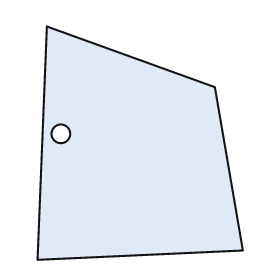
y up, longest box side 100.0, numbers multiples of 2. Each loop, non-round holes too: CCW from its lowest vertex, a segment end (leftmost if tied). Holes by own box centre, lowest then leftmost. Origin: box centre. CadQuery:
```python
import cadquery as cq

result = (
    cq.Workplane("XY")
    .moveTo(-44.0, -50.0)
    .lineTo(44.0, -46.0)
    .lineTo(32.0, 24.0)
    .lineTo(-40.0, 50.0)
    .close()
    .moveTo(-34.0, 4.0)
    .circle(4.0)
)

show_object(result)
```